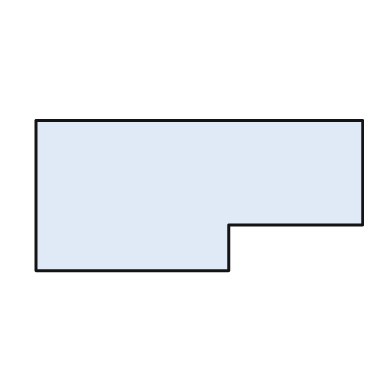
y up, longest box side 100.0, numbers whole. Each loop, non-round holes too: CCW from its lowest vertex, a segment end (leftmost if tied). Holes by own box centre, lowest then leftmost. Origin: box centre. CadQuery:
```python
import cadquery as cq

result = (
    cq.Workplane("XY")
    .moveTo(-50.0, -23.0)
    .lineTo(9.0, -23.0)
    .lineTo(9.0, -9.0)
    .lineTo(50.0, -9.0)
    .lineTo(50.0, 23.0)
    .lineTo(-50.0, 23.0)
    .close()
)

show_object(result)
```